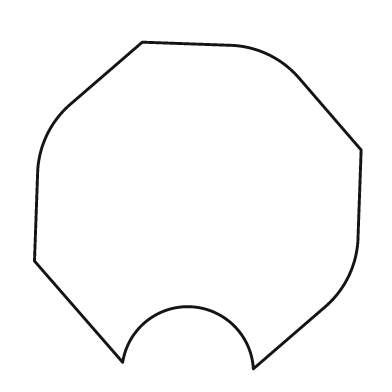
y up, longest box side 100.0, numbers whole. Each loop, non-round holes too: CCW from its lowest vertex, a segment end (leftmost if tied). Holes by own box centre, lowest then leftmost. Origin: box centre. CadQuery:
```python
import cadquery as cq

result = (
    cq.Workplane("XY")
    .moveTo(17.0, -50.0)
    .lineTo(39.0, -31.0)
    .threePointArc((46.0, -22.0), (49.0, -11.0))
    .lineTo(50.0, 17.0)
    .lineTo(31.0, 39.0)
    .threePointArc((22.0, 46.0), (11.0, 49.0))
    .lineTo(-17.0, 50.0)
    .lineTo(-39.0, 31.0)
    .threePointArc((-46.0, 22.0), (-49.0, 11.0))
    .lineTo(-50.0, -17.0)
    .lineTo(-23.0, -48.0)
    .threePointArc((-2.0, -31.0), (17.0, -50.0))
    .close()
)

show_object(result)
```